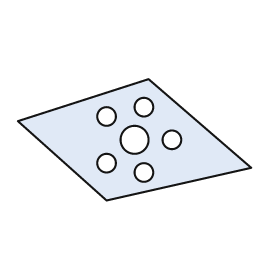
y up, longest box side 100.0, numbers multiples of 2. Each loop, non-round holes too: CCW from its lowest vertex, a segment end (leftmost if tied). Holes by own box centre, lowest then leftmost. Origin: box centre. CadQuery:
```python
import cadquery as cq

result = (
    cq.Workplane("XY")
    .moveTo(-12.0, -26.0)
    .lineTo(50.0, -12.0)
    .lineTo(6.0, 26.0)
    .lineTo(-50.0, 8.0)
    .close()
    .moveTo(4.0, -14.0)
    .circle(4.0)
    .moveTo(-12.0, -10.0)
    .circle(4.0)
    .moveTo(0.0, 0.0)
    .circle(6.0)
    .moveTo(16.0, 0.0)
    .circle(4.0)
    .moveTo(-12.0, 10.0)
    .circle(4.0)
    .moveTo(4.0, 14.0)
    .circle(4.0)
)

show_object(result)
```